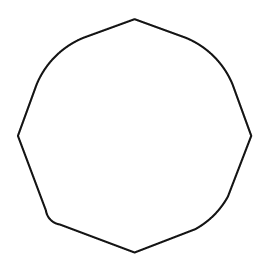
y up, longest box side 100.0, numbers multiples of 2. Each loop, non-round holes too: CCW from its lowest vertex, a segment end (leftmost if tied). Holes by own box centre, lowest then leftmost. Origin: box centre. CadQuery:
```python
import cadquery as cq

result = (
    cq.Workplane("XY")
    .moveTo(0.0, -50.0)
    .lineTo(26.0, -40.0)
    .threePointArc((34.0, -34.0), (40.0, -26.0))
    .lineTo(50.0, 0.0)
    .lineTo(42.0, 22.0)
    .threePointArc((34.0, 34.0), (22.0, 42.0))
    .lineTo(0.0, 50.0)
    .lineTo(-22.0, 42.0)
    .threePointArc((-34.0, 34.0), (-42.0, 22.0))
    .lineTo(-50.0, 0.0)
    .lineTo(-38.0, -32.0)
    .threePointArc((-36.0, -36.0), (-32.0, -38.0))
    .close()
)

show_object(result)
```